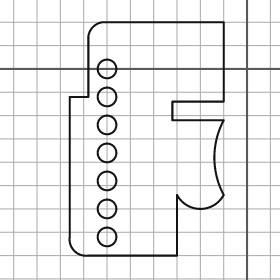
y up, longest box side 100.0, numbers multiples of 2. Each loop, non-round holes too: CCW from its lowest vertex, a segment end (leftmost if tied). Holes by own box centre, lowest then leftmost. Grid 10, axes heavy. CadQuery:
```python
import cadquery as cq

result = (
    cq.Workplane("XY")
    .moveTo(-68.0, -80.0)
    .lineTo(-30.0, -80.0)
    .lineTo(-30.0, -54.0)
    .threePointArc((-20.0, -60.0), (-10.0, -54.0))
    .threePointArc((-14.0, -38.0), (-10.0, -22.0))
    .lineTo(-32.0, -22.0)
    .lineTo(-32.0, -14.0)
    .lineTo(-10.0, -14.0)
    .lineTo(-10.0, 20.0)
    .lineTo(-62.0, 20.0)
    .threePointArc((-66.0, 18.0), (-68.0, 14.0))
    .lineTo(-68.0, -12.0)
    .lineTo(-76.0, -12.0)
    .lineTo(-76.0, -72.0)
    .threePointArc((-74.0, -78.0), (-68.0, -80.0))
    .close()
    .moveTo(-60.0, -72.0)
    .circle(4.0)
    .moveTo(-60.0, -60.0)
    .circle(4.0)
    .moveTo(-60.0, -48.0)
    .circle(4.0)
    .moveTo(-60.0, -36.0)
    .circle(4.0)
    .moveTo(-60.0, -24.0)
    .circle(4.0)
    .moveTo(-60.0, -12.0)
    .circle(4.0)
    .moveTo(-60.0, 0.0)
    .circle(4.0)
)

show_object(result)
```